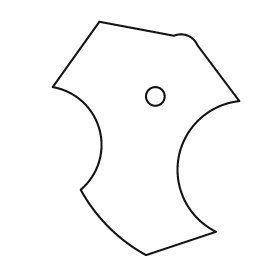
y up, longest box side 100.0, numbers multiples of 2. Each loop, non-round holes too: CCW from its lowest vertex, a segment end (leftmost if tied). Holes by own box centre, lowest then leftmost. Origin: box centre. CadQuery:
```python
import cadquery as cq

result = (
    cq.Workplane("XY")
    .moveTo(0.0, -50.0)
    .lineTo(30.0, -40.0)
    .threePointArc((14.0, -8.0), (40.0, 16.0))
    .lineTo(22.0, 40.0)
    .threePointArc((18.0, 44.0), (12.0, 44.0))
    .lineTo(-20.0, 50.0)
    .lineTo(-40.0, 22.0)
    .threePointArc((-20.0, 4.0), (-28.0, -22.0))
    .threePointArc((-16.0, -38.0), (0.0, -50.0))
    .close()
    .moveTo(4.0, 18.0)
    .circle(4.0)
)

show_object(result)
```